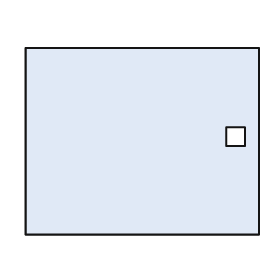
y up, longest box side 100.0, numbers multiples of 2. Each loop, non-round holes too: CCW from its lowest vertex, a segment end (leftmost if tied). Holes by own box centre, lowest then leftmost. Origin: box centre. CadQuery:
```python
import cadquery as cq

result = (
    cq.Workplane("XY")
    .moveTo(-50.0, -40.0)
    .lineTo(50.0, -40.0)
    .lineTo(50.0, 40.0)
    .lineTo(-50.0, 40.0)
    .close()
    .moveTo(36.0, -2.0)
    .lineTo(44.0, -2.0)
    .lineTo(44.0, 6.0)
    .lineTo(36.0, 6.0)
    .close()
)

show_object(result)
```